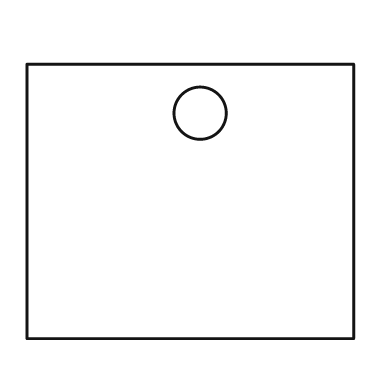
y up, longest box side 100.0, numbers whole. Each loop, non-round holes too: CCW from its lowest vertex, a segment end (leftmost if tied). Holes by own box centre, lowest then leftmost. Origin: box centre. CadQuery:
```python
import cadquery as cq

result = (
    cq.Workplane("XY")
    .moveTo(-50.0, -42.0)
    .lineTo(50.0, -42.0)
    .lineTo(50.0, 42.0)
    .lineTo(-50.0, 42.0)
    .close()
    .moveTo(3.0, 27.0)
    .circle(8.0)
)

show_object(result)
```